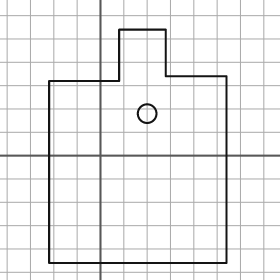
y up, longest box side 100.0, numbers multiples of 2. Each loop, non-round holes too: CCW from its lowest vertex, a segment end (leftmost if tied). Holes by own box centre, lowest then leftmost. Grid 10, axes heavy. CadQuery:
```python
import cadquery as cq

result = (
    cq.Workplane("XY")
    .moveTo(-22.0, -46.0)
    .lineTo(54.0, -46.0)
    .lineTo(54.0, 34.0)
    .lineTo(28.0, 34.0)
    .lineTo(28.0, 54.0)
    .lineTo(8.0, 54.0)
    .lineTo(8.0, 32.0)
    .lineTo(-22.0, 32.0)
    .close()
    .moveTo(20.0, 18.0)
    .circle(4.0)
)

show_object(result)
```